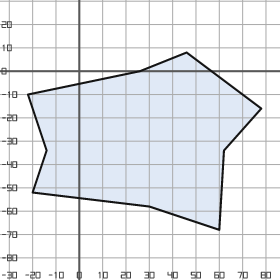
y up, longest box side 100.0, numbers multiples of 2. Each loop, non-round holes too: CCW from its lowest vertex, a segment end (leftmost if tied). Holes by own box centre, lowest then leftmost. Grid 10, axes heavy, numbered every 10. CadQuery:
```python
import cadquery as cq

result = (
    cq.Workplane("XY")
    .moveTo(60.0, -68.0)
    .lineTo(62.0, -34.0)
    .lineTo(78.0, -16.0)
    .lineTo(46.0, 8.0)
    .lineTo(26.0, 0.0)
    .lineTo(-22.0, -10.0)
    .lineTo(-14.0, -34.0)
    .lineTo(-20.0, -52.0)
    .lineTo(30.0, -58.0)
    .close()
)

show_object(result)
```